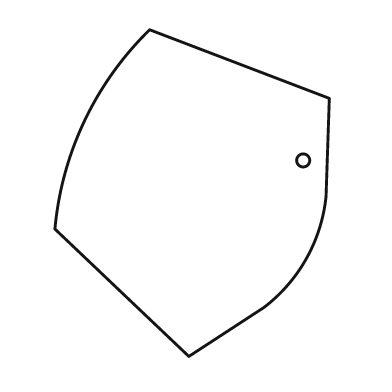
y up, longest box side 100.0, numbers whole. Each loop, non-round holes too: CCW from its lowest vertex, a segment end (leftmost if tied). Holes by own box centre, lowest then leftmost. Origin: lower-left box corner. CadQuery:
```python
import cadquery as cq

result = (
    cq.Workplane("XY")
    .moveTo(41.0, 0.0)
    .lineTo(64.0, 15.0)
    .threePointArc((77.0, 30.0), (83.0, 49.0))
    .lineTo(84.0, 79.0)
    .lineTo(29.0, 100.0)
    .threePointArc((9.0, 72.0), (0.0, 39.0))
    .close()
    .moveTo(76.0, 60.0)
    .circle(2.0)
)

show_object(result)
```